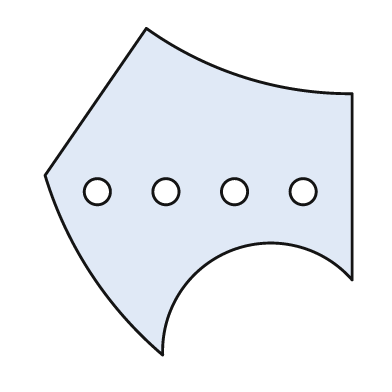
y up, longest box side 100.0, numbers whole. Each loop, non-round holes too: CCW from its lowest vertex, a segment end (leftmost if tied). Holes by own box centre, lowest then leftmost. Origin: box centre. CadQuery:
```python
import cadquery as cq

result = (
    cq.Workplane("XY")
    .moveTo(-11.0, -50.0)
    .threePointArc((10.0, -18.0), (47.0, -27.0))
    .lineTo(47.0, 30.0)
    .threePointArc((14.0, 35.0), (-16.0, 50.0))
    .lineTo(-47.0, 5.0)
    .threePointArc((-33.0, -25.0), (-11.0, -50.0))
    .close()
    .moveTo(-31.0, 0.0)
    .circle(4.0)
    .moveTo(-10.0, 0.0)
    .circle(4.0)
    .moveTo(11.0, 0.0)
    .circle(4.0)
    .moveTo(32.0, 0.0)
    .circle(4.0)
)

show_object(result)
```